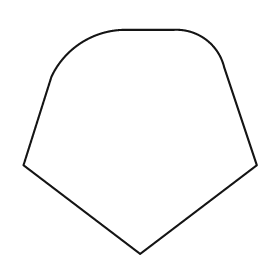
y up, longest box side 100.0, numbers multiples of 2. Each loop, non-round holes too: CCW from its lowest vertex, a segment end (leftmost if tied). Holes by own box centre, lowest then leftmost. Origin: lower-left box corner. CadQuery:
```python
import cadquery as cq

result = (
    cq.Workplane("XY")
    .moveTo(50.0, 0.0)
    .lineTo(100.0, 38.0)
    .lineTo(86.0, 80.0)
    .threePointArc((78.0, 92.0), (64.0, 96.0))
    .lineTo(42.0, 96.0)
    .threePointArc((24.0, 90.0), (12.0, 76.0))
    .lineTo(0.0, 38.0)
    .close()
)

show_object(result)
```